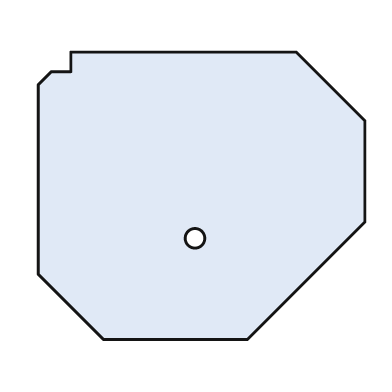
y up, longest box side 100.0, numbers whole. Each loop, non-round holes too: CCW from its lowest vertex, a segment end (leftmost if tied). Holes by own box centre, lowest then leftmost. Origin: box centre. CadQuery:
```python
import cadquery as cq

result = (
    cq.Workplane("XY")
    .moveTo(-30.0, -44.0)
    .lineTo(14.0, -44.0)
    .lineTo(50.0, -8.0)
    .lineTo(50.0, 23.0)
    .lineTo(29.0, 44.0)
    .lineTo(-40.0, 44.0)
    .lineTo(-40.0, 38.0)
    .lineTo(-46.0, 38.0)
    .lineTo(-50.0, 34.0)
    .lineTo(-50.0, -24.0)
    .close()
    .moveTo(-2.0, -13.0)
    .circle(3.0)
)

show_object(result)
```